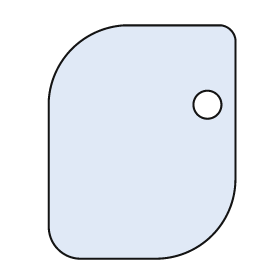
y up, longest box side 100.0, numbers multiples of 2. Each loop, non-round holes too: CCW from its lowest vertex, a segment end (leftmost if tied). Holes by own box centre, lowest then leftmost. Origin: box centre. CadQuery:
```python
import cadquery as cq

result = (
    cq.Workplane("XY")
    .moveTo(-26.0, -50.0)
    .lineTo(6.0, -50.0)
    .threePointArc((30.0, -40.0), (40.0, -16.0))
    .lineTo(40.0, 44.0)
    .threePointArc((38.0, 48.0), (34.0, 50.0))
    .lineTo(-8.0, 50.0)
    .threePointArc((-30.0, 40.0), (-40.0, 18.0))
    .lineTo(-40.0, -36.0)
    .threePointArc((-36.0, -46.0), (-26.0, -50.0))
    .close()
    .moveTo(28.0, 16.0)
    .circle(6.0)
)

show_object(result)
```